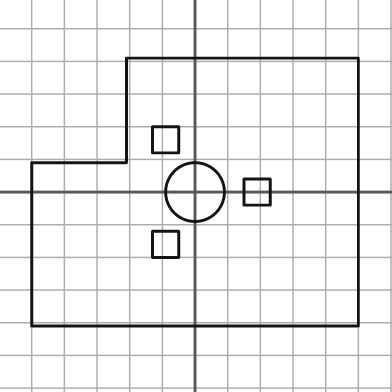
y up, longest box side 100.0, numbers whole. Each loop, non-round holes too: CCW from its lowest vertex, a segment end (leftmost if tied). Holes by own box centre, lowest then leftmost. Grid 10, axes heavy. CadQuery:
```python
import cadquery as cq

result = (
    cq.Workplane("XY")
    .moveTo(-50.0, -41.0)
    .lineTo(50.0, -41.0)
    .lineTo(50.0, 41.0)
    .lineTo(-21.0, 41.0)
    .lineTo(-21.0, 9.0)
    .lineTo(-50.0, 9.0)
    .close()
    .moveTo(-13.0, -20.0)
    .lineTo(-5.0, -20.0)
    .lineTo(-5.0, -12.0)
    .lineTo(-13.0, -12.0)
    .close()
    .moveTo(0.0, 0.0)
    .circle(9.0)
    .moveTo(15.0, -4.0)
    .lineTo(23.0, -4.0)
    .lineTo(23.0, 4.0)
    .lineTo(15.0, 4.0)
    .close()
    .moveTo(-13.0, 12.0)
    .lineTo(-5.0, 12.0)
    .lineTo(-5.0, 20.0)
    .lineTo(-13.0, 20.0)
    .close()
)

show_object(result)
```